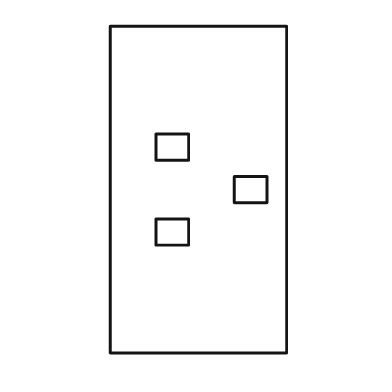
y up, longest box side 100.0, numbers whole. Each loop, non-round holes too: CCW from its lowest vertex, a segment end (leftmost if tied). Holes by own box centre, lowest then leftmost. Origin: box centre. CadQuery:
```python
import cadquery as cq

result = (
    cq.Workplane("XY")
    .moveTo(-27.0, -50.0)
    .lineTo(27.0, -50.0)
    .lineTo(27.0, 50.0)
    .lineTo(-27.0, 50.0)
    .close()
    .moveTo(-13.0, -17.0)
    .lineTo(-3.0, -17.0)
    .lineTo(-3.0, -9.0)
    .lineTo(-13.0, -9.0)
    .close()
    .moveTo(11.0, -4.0)
    .lineTo(21.0, -4.0)
    .lineTo(21.0, 4.0)
    .lineTo(11.0, 4.0)
    .close()
    .moveTo(-13.0, 9.0)
    .lineTo(-3.0, 9.0)
    .lineTo(-3.0, 17.0)
    .lineTo(-13.0, 17.0)
    .close()
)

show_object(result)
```